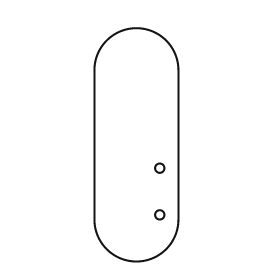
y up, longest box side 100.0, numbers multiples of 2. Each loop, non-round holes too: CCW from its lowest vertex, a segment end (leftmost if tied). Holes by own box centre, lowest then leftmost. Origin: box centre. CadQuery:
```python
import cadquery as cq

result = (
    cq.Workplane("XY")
    .moveTo(-18.0, -32.0)
    .threePointArc((0.0, -50.0), (18.0, -32.0))
    .lineTo(18.0, 32.0)
    .threePointArc((0.0, 50.0), (-18.0, 32.0))
    .close()
    .moveTo(10.0, -30.0)
    .circle(2.0)
    .moveTo(10.0, -10.0)
    .circle(2.0)
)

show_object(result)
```